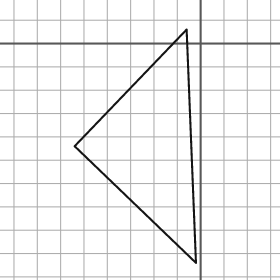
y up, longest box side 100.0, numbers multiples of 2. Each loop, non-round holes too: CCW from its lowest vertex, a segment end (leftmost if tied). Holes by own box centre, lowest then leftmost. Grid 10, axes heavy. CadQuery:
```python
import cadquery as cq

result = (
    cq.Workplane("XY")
    .moveTo(-2.0, -94.0)
    .lineTo(-6.0, 6.0)
    .lineTo(-54.0, -44.0)
    .close()
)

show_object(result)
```